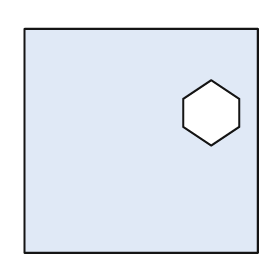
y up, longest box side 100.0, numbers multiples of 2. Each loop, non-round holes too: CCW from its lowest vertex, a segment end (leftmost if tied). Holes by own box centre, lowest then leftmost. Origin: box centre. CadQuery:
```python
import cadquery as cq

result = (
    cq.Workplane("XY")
    .moveTo(-50.0, -48.0)
    .lineTo(50.0, -48.0)
    .lineTo(50.0, 48.0)
    .lineTo(-50.0, 48.0)
    .close()
    .moveTo(30.0, -2.0)
    .lineTo(42.0, 6.0)
    .lineTo(42.0, 18.0)
    .lineTo(30.0, 26.0)
    .lineTo(18.0, 18.0)
    .lineTo(18.0, 6.0)
    .close()
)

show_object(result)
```